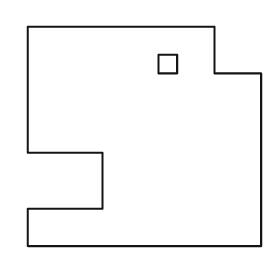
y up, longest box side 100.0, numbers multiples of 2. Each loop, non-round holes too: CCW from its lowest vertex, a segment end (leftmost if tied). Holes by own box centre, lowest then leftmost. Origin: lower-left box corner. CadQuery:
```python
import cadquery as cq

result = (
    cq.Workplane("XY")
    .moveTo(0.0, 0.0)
    .lineTo(100.0, 0.0)
    .lineTo(100.0, 74.0)
    .lineTo(80.0, 74.0)
    .lineTo(80.0, 94.0)
    .lineTo(0.0, 94.0)
    .lineTo(0.0, 40.0)
    .lineTo(32.0, 40.0)
    .lineTo(32.0, 16.0)
    .lineTo(0.0, 16.0)
    .close()
    .moveTo(56.0, 74.0)
    .lineTo(64.0, 74.0)
    .lineTo(64.0, 82.0)
    .lineTo(56.0, 82.0)
    .close()
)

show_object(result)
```